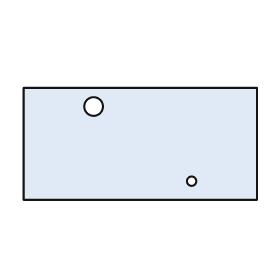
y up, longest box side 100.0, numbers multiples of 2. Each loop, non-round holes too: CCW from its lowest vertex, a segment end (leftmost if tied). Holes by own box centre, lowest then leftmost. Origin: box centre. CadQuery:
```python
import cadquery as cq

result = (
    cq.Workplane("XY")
    .moveTo(-50.0, -24.0)
    .lineTo(50.0, -24.0)
    .lineTo(50.0, 24.0)
    .lineTo(-50.0, 24.0)
    .close()
    .moveTo(22.0, -16.0)
    .circle(2.0)
    .moveTo(-20.0, 16.0)
    .circle(4.0)
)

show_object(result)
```